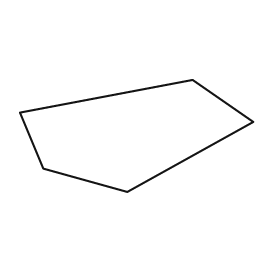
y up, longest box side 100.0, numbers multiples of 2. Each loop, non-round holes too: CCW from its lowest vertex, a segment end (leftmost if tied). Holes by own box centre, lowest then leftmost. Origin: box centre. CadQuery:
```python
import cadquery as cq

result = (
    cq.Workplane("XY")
    .moveTo(-4.0, -24.0)
    .lineTo(50.0, 6.0)
    .lineTo(24.0, 24.0)
    .lineTo(-50.0, 10.0)
    .lineTo(-40.0, -14.0)
    .close()
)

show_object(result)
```